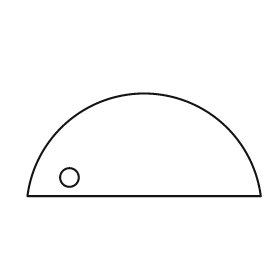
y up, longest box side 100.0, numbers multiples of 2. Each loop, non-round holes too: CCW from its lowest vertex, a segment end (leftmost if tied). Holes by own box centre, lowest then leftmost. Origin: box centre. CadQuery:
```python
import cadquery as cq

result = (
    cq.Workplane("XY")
    .moveTo(-50.0, -22.0)
    .lineTo(50.0, -22.0)
    .threePointArc((0.0, 22.0), (-50.0, -22.0))
    .close()
    .moveTo(-32.0, -14.0)
    .circle(4.0)
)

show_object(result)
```